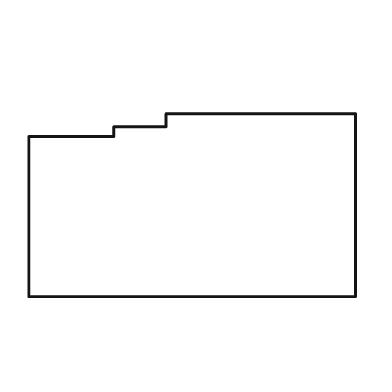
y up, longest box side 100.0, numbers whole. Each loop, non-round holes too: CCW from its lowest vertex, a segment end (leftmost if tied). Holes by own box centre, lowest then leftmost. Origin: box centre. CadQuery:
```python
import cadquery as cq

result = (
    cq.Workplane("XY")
    .moveTo(-50.0, -28.0)
    .lineTo(50.0, -28.0)
    .lineTo(50.0, 28.0)
    .lineTo(-8.0, 28.0)
    .lineTo(-8.0, 24.0)
    .lineTo(-24.0, 24.0)
    .lineTo(-24.0, 21.0)
    .lineTo(-50.0, 21.0)
    .close()
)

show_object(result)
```